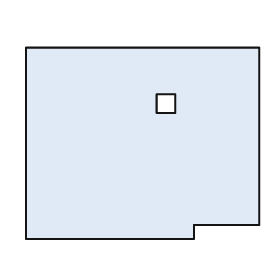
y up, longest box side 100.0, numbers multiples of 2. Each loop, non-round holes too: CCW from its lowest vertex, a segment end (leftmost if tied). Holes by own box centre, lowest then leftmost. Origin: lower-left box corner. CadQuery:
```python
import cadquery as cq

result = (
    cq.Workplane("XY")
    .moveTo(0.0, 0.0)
    .lineTo(72.0, 0.0)
    .lineTo(72.0, 6.0)
    .lineTo(100.0, 6.0)
    .lineTo(100.0, 82.0)
    .lineTo(0.0, 82.0)
    .close()
    .moveTo(56.0, 54.0)
    .lineTo(64.0, 54.0)
    .lineTo(64.0, 62.0)
    .lineTo(56.0, 62.0)
    .close()
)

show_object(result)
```